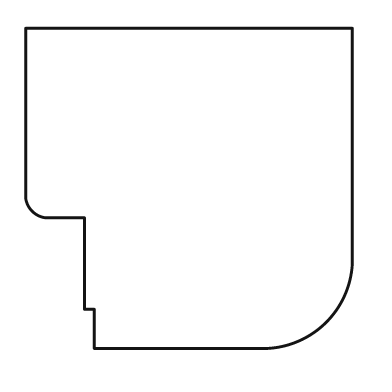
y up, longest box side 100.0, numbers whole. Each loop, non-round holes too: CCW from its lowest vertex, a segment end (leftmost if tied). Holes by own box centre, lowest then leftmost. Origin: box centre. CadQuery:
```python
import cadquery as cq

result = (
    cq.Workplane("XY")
    .moveTo(-29.0, -49.0)
    .lineTo(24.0, -49.0)
    .threePointArc((42.0, -41.0), (50.0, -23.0))
    .lineTo(50.0, 49.0)
    .lineTo(-50.0, 49.0)
    .lineTo(-50.0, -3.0)
    .threePointArc((-48.0, -7.0), (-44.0, -9.0))
    .lineTo(-32.0, -9.0)
    .lineTo(-32.0, -37.0)
    .lineTo(-29.0, -37.0)
    .close()
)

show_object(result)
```